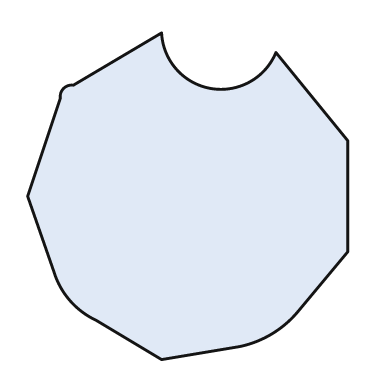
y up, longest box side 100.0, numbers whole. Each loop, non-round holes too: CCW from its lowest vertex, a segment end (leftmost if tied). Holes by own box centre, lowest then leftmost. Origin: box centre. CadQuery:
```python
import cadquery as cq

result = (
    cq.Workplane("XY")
    .moveTo(-8.0, -50.0)
    .lineTo(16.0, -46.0)
    .threePointArc((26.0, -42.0), (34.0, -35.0))
    .lineTo(49.0, -17.0)
    .lineTo(49.0, 17.0)
    .lineTo(27.0, 44.0)
    .threePointArc((7.0, 33.0), (-8.0, 50.0))
    .lineTo(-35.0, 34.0)
    .threePointArc((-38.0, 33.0), (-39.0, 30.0))
    .lineTo(-49.0, 0.0)
    .lineTo(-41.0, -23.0)
    .threePointArc((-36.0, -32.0), (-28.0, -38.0))
    .close()
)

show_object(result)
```